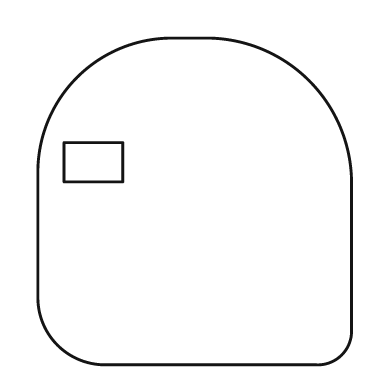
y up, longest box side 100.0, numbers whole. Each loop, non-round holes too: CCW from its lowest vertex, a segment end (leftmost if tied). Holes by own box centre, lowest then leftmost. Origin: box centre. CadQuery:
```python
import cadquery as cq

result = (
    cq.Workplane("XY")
    .moveTo(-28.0, -50.0)
    .lineTo(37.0, -50.0)
    .threePointArc((45.0, -47.0), (48.0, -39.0))
    .lineTo(48.0, 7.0)
    .threePointArc((35.0, 37.0), (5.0, 50.0))
    .lineTo(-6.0, 50.0)
    .threePointArc((-36.0, 38.0), (-48.0, 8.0))
    .lineTo(-48.0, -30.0)
    .threePointArc((-42.0, -44.0), (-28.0, -50.0))
    .close()
    .moveTo(-40.0, 6.0)
    .lineTo(-22.0, 6.0)
    .lineTo(-22.0, 18.0)
    .lineTo(-40.0, 18.0)
    .close()
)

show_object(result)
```